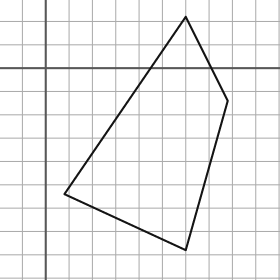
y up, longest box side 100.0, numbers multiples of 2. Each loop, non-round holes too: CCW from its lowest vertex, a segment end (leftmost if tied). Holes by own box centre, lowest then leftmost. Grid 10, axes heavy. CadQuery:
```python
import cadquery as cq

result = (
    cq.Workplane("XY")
    .moveTo(60.0, -78.0)
    .lineTo(78.0, -14.0)
    .lineTo(60.0, 22.0)
    .lineTo(8.0, -54.0)
    .close()
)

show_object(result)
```